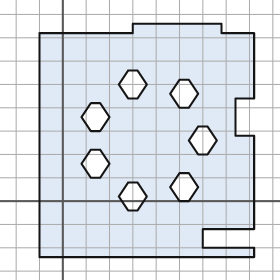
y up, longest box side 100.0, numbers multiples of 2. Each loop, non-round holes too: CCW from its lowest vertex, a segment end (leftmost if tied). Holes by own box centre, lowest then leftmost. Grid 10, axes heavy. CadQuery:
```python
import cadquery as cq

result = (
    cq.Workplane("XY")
    .moveTo(-10.0, -24.0)
    .lineTo(82.0, -24.0)
    .lineTo(82.0, -20.0)
    .lineTo(60.0, -20.0)
    .lineTo(60.0, -12.0)
    .lineTo(82.0, -12.0)
    .lineTo(82.0, 28.0)
    .lineTo(74.0, 28.0)
    .lineTo(74.0, 44.0)
    .lineTo(82.0, 44.0)
    .lineTo(82.0, 72.0)
    .lineTo(68.0, 72.0)
    .lineTo(68.0, 76.0)
    .lineTo(30.0, 76.0)
    .lineTo(30.0, 72.0)
    .lineTo(-10.0, 72.0)
    .close()
    .moveTo(28.0, -4.0)
    .lineTo(32.0, -4.0)
    .lineTo(36.0, 2.0)
    .lineTo(32.0, 8.0)
    .lineTo(28.0, 8.0)
    .lineTo(24.0, 2.0)
    .close()
    .moveTo(50.0, 0.0)
    .lineTo(54.0, 0.0)
    .lineTo(58.0, 6.0)
    .lineTo(54.0, 12.0)
    .lineTo(50.0, 12.0)
    .lineTo(46.0, 6.0)
    .close()
    .moveTo(12.0, 10.0)
    .lineTo(16.0, 10.0)
    .lineTo(20.0, 16.0)
    .lineTo(16.0, 22.0)
    .lineTo(12.0, 22.0)
    .lineTo(8.0, 16.0)
    .close()
    .moveTo(58.0, 20.0)
    .lineTo(62.0, 20.0)
    .lineTo(66.0, 26.0)
    .lineTo(62.0, 32.0)
    .lineTo(58.0, 32.0)
    .lineTo(54.0, 26.0)
    .close()
    .moveTo(12.0, 30.0)
    .lineTo(16.0, 30.0)
    .lineTo(20.0, 36.0)
    .lineTo(16.0, 42.0)
    .lineTo(12.0, 42.0)
    .lineTo(8.0, 36.0)
    .close()
    .moveTo(50.0, 40.0)
    .lineTo(54.0, 40.0)
    .lineTo(58.0, 46.0)
    .lineTo(54.0, 52.0)
    .lineTo(50.0, 52.0)
    .lineTo(46.0, 46.0)
    .close()
    .moveTo(28.0, 44.0)
    .lineTo(32.0, 44.0)
    .lineTo(36.0, 50.0)
    .lineTo(32.0, 56.0)
    .lineTo(28.0, 56.0)
    .lineTo(24.0, 50.0)
    .close()
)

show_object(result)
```